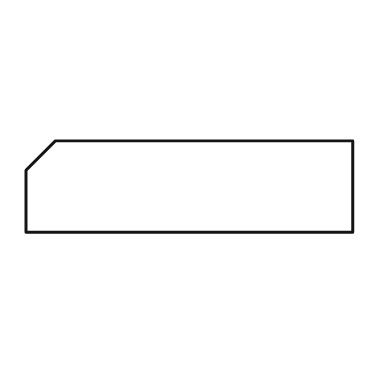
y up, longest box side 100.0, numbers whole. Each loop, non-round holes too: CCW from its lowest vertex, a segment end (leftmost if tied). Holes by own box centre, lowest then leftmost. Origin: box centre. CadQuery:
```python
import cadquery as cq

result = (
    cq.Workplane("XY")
    .moveTo(-50.0, -14.0)
    .lineTo(50.0, -14.0)
    .lineTo(50.0, 14.0)
    .lineTo(-41.0, 14.0)
    .lineTo(-50.0, 5.0)
    .close()
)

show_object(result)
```